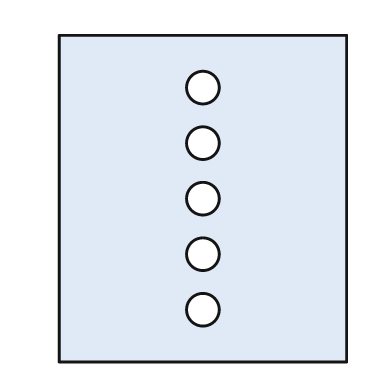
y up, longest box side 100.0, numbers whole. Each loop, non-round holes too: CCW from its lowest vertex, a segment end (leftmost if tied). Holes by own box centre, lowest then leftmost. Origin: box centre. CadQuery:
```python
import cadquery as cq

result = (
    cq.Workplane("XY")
    .moveTo(-44.0, -50.0)
    .lineTo(44.0, -50.0)
    .lineTo(44.0, 50.0)
    .lineTo(-44.0, 50.0)
    .close()
    .moveTo(0.0, -34.0)
    .circle(5.0)
    .moveTo(0.0, -17.0)
    .circle(5.0)
    .moveTo(0.0, 0.0)
    .circle(5.0)
    .moveTo(0.0, 17.0)
    .circle(5.0)
    .moveTo(0.0, 34.0)
    .circle(5.0)
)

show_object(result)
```